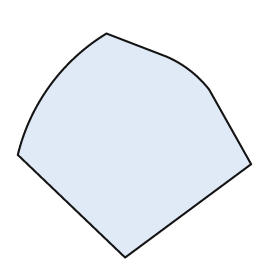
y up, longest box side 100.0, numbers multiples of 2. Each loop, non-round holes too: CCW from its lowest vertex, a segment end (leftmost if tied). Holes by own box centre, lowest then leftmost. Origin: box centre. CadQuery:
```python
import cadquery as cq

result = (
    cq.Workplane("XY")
    .moveTo(-4.0, -48.0)
    .lineTo(50.0, -8.0)
    .lineTo(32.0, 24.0)
    .threePointArc((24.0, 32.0), (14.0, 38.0))
    .lineTo(-12.0, 48.0)
    .threePointArc((-36.0, 26.0), (-50.0, -4.0))
    .close()
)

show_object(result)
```